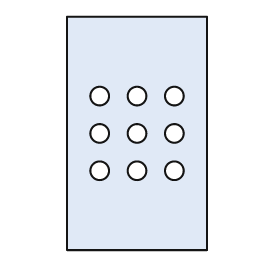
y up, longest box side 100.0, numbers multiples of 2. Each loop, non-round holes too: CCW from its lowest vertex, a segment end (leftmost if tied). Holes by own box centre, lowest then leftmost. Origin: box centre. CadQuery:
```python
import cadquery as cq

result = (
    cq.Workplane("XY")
    .moveTo(-30.0, -50.0)
    .lineTo(30.0, -50.0)
    .lineTo(30.0, 50.0)
    .lineTo(-30.0, 50.0)
    .close()
    .moveTo(-16.0, -16.0)
    .circle(4.0)
    .moveTo(0.0, -16.0)
    .circle(4.0)
    .moveTo(16.0, -16.0)
    .circle(4.0)
    .moveTo(-16.0, 0.0)
    .circle(4.0)
    .moveTo(0.0, 0.0)
    .circle(4.0)
    .moveTo(16.0, 0.0)
    .circle(4.0)
    .moveTo(-16.0, 16.0)
    .circle(4.0)
    .moveTo(0.0, 16.0)
    .circle(4.0)
    .moveTo(16.0, 16.0)
    .circle(4.0)
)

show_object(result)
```